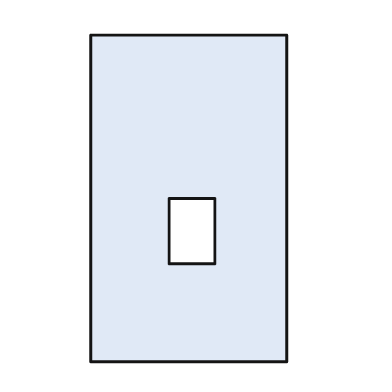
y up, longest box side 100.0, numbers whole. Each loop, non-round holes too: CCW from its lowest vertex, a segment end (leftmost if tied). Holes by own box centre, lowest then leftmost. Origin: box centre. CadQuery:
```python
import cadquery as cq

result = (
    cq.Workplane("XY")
    .moveTo(-30.0, -50.0)
    .lineTo(30.0, -50.0)
    .lineTo(30.0, 50.0)
    .lineTo(-30.0, 50.0)
    .close()
    .moveTo(-6.0, -20.0)
    .lineTo(8.0, -20.0)
    .lineTo(8.0, 0.0)
    .lineTo(-6.0, 0.0)
    .close()
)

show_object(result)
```